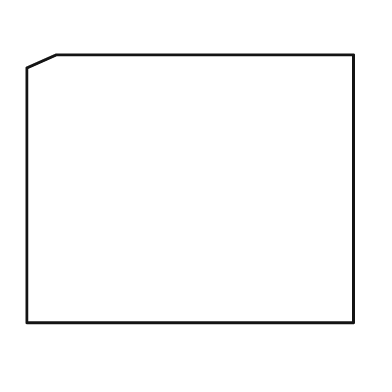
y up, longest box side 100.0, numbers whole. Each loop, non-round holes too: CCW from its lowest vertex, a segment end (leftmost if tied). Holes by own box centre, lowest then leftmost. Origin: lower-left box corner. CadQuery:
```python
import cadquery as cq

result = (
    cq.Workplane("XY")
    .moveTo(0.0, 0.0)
    .lineTo(100.0, 0.0)
    .lineTo(100.0, 82.0)
    .lineTo(9.0, 82.0)
    .lineTo(0.0, 78.0)
    .close()
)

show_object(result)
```